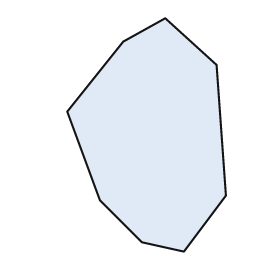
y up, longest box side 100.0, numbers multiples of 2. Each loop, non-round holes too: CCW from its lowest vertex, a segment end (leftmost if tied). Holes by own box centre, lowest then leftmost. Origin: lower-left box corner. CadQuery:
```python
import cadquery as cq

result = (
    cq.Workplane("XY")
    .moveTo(50.0, 0.0)
    .lineTo(68.0, 24.0)
    .lineTo(64.0, 80.0)
    .lineTo(42.0, 100.0)
    .lineTo(24.0, 90.0)
    .lineTo(0.0, 60.0)
    .lineTo(14.0, 22.0)
    .lineTo(32.0, 4.0)
    .close()
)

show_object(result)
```